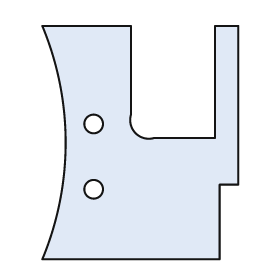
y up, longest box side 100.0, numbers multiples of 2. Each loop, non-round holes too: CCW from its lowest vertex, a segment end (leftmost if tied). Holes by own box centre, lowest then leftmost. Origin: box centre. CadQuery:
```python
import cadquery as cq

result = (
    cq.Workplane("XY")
    .moveTo(-42.0, -50.0)
    .lineTo(34.0, -50.0)
    .lineTo(34.0, -18.0)
    .lineTo(42.0, -18.0)
    .lineTo(42.0, 50.0)
    .lineTo(32.0, 50.0)
    .lineTo(32.0, 2.0)
    .lineTo(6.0, 2.0)
    .threePointArc((-2.0, 4.0), (-4.0, 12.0))
    .lineTo(-4.0, 50.0)
    .lineTo(-42.0, 50.0)
    .threePointArc((-32.0, 0.0), (-42.0, -50.0))
    .close()
    .moveTo(-20.0, -20.0)
    .circle(4.0)
    .moveTo(-20.0, 8.0)
    .circle(4.0)
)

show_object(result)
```